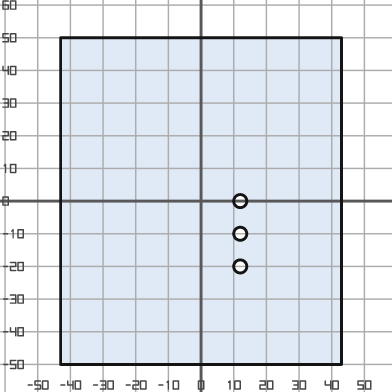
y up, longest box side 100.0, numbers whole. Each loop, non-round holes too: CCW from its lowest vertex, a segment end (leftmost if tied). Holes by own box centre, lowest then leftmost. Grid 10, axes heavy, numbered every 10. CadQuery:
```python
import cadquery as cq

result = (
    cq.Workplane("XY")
    .moveTo(-43.0, -50.0)
    .lineTo(43.0, -50.0)
    .lineTo(43.0, 50.0)
    .lineTo(-43.0, 50.0)
    .close()
    .moveTo(12.0, -20.0)
    .circle(2.0)
    .moveTo(12.0, -10.0)
    .circle(2.0)
    .moveTo(12.0, 0.0)
    .circle(2.0)
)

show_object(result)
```